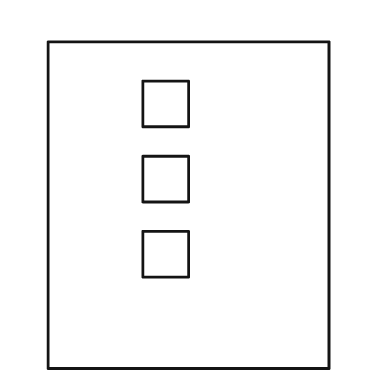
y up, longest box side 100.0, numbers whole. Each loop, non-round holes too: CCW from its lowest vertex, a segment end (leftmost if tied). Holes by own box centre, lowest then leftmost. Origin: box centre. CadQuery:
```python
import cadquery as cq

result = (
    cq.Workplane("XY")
    .moveTo(-43.0, -50.0)
    .lineTo(43.0, -50.0)
    .lineTo(43.0, 50.0)
    .lineTo(-43.0, 50.0)
    .close()
    .moveTo(-14.0, -22.0)
    .lineTo(0.0, -22.0)
    .lineTo(0.0, -8.0)
    .lineTo(-14.0, -8.0)
    .close()
    .moveTo(-14.0, 1.0)
    .lineTo(0.0, 1.0)
    .lineTo(0.0, 15.0)
    .lineTo(-14.0, 15.0)
    .close()
    .moveTo(-14.0, 24.0)
    .lineTo(0.0, 24.0)
    .lineTo(0.0, 38.0)
    .lineTo(-14.0, 38.0)
    .close()
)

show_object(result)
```